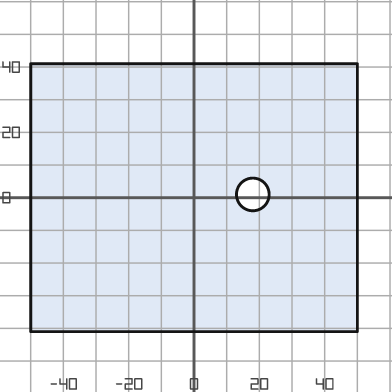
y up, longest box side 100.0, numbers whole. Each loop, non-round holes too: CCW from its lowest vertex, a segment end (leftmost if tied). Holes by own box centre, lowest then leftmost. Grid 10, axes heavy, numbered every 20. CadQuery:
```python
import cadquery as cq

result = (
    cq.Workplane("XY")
    .moveTo(-50.0, -41.0)
    .lineTo(50.0, -41.0)
    .lineTo(50.0, 41.0)
    .lineTo(-50.0, 41.0)
    .close()
    .moveTo(18.0, 1.0)
    .circle(5.0)
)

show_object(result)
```